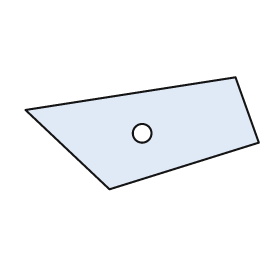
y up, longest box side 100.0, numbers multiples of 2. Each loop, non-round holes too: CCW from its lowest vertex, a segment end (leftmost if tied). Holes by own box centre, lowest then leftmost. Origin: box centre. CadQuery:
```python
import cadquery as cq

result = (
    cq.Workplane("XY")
    .moveTo(-14.0, -24.0)
    .lineTo(50.0, -4.0)
    .lineTo(40.0, 24.0)
    .lineTo(-50.0, 10.0)
    .close()
    .moveTo(0.0, 0.0)
    .circle(4.0)
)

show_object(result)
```